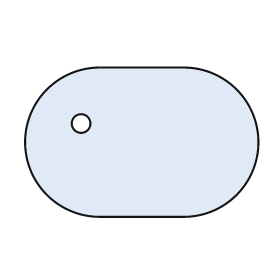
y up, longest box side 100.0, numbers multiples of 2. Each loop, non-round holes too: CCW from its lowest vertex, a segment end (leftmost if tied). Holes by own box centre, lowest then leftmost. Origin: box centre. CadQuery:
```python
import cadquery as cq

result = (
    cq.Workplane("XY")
    .moveTo(-18.0, -32.0)
    .lineTo(18.0, -32.0)
    .threePointArc((50.0, 0.0), (18.0, 32.0))
    .lineTo(-18.0, 32.0)
    .threePointArc((-50.0, 0.0), (-18.0, -32.0))
    .close()
    .moveTo(-26.0, 8.0)
    .circle(4.0)
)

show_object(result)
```